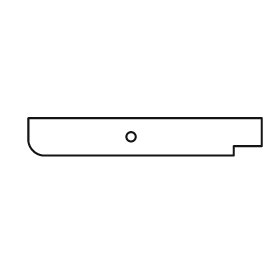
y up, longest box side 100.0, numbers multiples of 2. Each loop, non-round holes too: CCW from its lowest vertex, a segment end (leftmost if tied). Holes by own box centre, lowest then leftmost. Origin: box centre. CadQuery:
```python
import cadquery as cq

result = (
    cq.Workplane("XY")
    .moveTo(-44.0, -8.0)
    .lineTo(38.0, -8.0)
    .lineTo(38.0, -4.0)
    .lineTo(50.0, -4.0)
    .lineTo(50.0, 8.0)
    .lineTo(-50.0, 8.0)
    .lineTo(-50.0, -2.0)
    .threePointArc((-48.0, -6.0), (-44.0, -8.0))
    .close()
    .moveTo(-6.0, 0.0)
    .circle(2.0)
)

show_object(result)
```